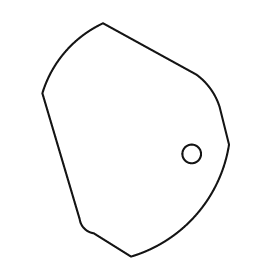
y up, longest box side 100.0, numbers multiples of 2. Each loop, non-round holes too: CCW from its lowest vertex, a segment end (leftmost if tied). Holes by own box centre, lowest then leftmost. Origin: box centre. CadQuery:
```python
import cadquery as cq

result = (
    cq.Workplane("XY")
    .moveTo(-2.0, -50.0)
    .threePointArc((26.0, -32.0), (40.0, -2.0))
    .lineTo(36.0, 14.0)
    .threePointArc((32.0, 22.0), (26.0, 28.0))
    .lineTo(-14.0, 50.0)
    .threePointArc((-30.0, 38.0), (-40.0, 20.0))
    .lineTo(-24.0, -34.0)
    .threePointArc((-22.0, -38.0), (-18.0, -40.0))
    .close()
    .moveTo(24.0, -6.0)
    .circle(4.0)
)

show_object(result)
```